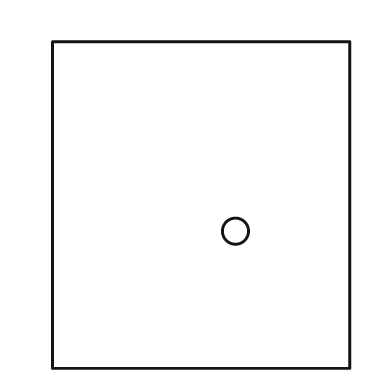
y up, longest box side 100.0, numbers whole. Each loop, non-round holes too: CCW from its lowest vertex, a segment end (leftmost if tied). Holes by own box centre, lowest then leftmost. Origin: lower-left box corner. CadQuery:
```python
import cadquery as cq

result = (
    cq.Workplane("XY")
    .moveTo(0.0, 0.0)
    .lineTo(91.0, 0.0)
    .lineTo(91.0, 100.0)
    .lineTo(0.0, 100.0)
    .close()
    .moveTo(56.0, 42.0)
    .circle(4.0)
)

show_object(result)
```